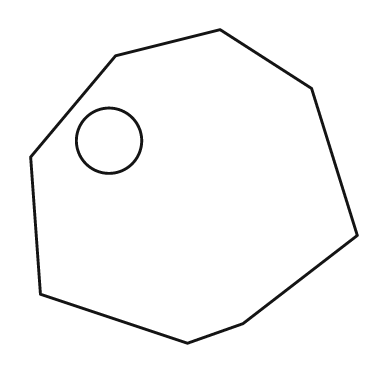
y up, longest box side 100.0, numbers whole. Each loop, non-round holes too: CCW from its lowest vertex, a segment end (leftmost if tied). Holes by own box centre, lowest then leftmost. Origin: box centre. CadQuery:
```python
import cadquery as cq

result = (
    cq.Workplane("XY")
    .moveTo(-2.0, -48.0)
    .lineTo(15.0, -42.0)
    .lineTo(50.0, -15.0)
    .lineTo(36.0, 30.0)
    .lineTo(8.0, 48.0)
    .lineTo(-24.0, 40.0)
    .lineTo(-50.0, 9.0)
    .lineTo(-47.0, -33.0)
    .close()
    .moveTo(-26.0, 14.0)
    .circle(10.0)
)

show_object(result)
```